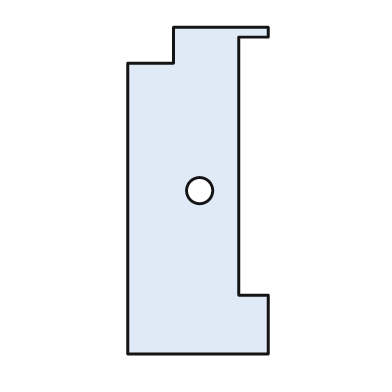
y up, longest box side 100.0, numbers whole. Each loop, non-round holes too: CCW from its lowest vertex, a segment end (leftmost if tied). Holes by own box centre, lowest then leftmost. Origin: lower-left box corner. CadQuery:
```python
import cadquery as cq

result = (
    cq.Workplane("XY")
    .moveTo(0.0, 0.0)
    .lineTo(43.0, 0.0)
    .lineTo(43.0, 18.0)
    .lineTo(34.0, 18.0)
    .lineTo(34.0, 97.0)
    .lineTo(43.0, 97.0)
    .lineTo(43.0, 100.0)
    .lineTo(14.0, 100.0)
    .lineTo(14.0, 89.0)
    .lineTo(0.0, 89.0)
    .close()
    .moveTo(22.0, 50.0)
    .circle(4.0)
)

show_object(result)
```